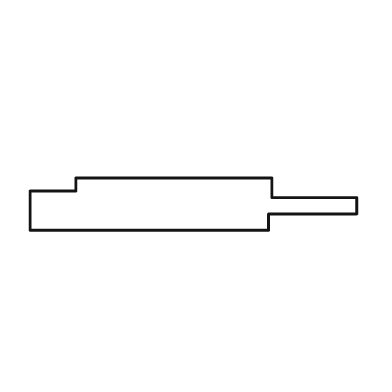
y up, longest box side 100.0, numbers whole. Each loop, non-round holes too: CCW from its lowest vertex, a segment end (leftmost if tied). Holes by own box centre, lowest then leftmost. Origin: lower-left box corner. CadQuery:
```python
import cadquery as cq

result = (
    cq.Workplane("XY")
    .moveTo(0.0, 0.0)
    .lineTo(73.0, 0.0)
    .lineTo(73.0, 5.0)
    .lineTo(100.0, 5.0)
    .lineTo(100.0, 10.0)
    .lineTo(74.0, 10.0)
    .lineTo(74.0, 16.0)
    .lineTo(14.0, 16.0)
    .lineTo(14.0, 12.0)
    .lineTo(0.0, 12.0)
    .close()
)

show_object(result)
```